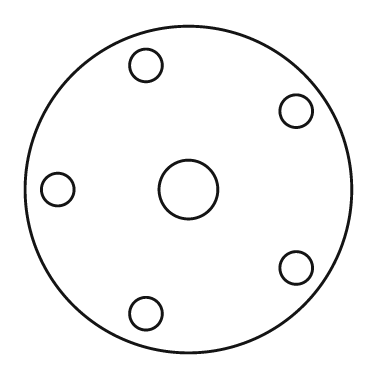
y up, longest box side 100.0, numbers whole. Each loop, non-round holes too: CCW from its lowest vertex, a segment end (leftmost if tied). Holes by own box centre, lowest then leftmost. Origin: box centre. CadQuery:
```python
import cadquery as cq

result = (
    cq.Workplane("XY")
    .moveTo(0.0, 0.0)
    .circle(50.0)
    .moveTo(-13.0, -38.0)
    .circle(5.0)
    .moveTo(33.0, -24.0)
    .circle(5.0)
    .moveTo(-40.0, 0.0)
    .circle(5.0)
    .moveTo(0.0, 0.0)
    .circle(9.0)
    .moveTo(33.0, 24.0)
    .circle(5.0)
    .moveTo(-13.0, 38.0)
    .circle(5.0)
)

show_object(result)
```